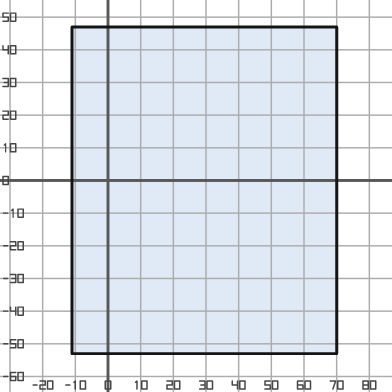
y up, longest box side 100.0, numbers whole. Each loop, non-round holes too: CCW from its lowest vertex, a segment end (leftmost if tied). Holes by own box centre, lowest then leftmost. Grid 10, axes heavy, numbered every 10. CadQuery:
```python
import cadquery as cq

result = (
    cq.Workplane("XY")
    .moveTo(-11.0, -53.0)
    .lineTo(70.0, -53.0)
    .lineTo(70.0, 47.0)
    .lineTo(-11.0, 47.0)
    .close()
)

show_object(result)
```